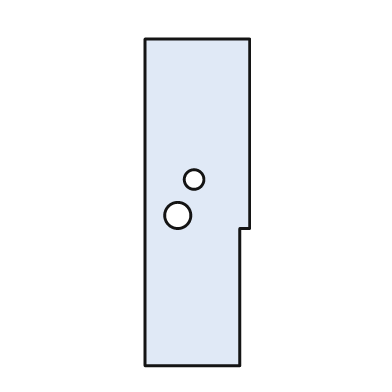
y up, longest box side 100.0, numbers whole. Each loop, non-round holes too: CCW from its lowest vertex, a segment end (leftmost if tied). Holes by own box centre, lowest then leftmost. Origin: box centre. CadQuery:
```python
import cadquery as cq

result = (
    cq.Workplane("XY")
    .moveTo(-16.0, -50.0)
    .lineTo(13.0, -50.0)
    .lineTo(13.0, -8.0)
    .lineTo(16.0, -8.0)
    .lineTo(16.0, 50.0)
    .lineTo(-16.0, 50.0)
    .close()
    .moveTo(-6.0, -4.0)
    .circle(4.0)
    .moveTo(-1.0, 7.0)
    .circle(3.0)
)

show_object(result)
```